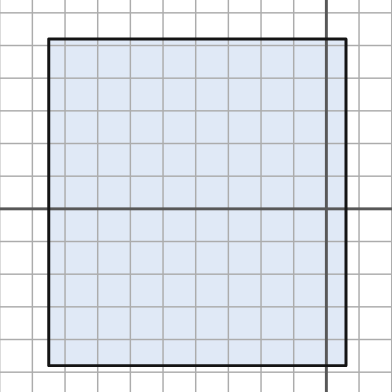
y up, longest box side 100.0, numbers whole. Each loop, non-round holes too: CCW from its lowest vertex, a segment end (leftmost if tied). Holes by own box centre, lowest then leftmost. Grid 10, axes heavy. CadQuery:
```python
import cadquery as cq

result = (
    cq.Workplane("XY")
    .moveTo(-85.0, -48.0)
    .lineTo(6.0, -48.0)
    .lineTo(6.0, 52.0)
    .lineTo(-85.0, 52.0)
    .close()
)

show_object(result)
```